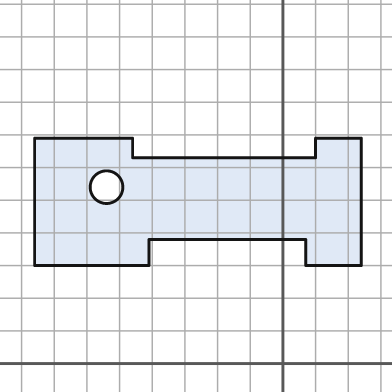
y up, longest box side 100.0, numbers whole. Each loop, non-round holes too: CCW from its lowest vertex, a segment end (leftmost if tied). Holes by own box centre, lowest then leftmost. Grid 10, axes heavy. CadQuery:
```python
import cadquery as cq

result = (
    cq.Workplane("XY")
    .moveTo(-76.0, 30.0)
    .lineTo(-41.0, 30.0)
    .lineTo(-41.0, 38.0)
    .lineTo(7.0, 38.0)
    .lineTo(7.0, 30.0)
    .lineTo(24.0, 30.0)
    .lineTo(24.0, 69.0)
    .lineTo(10.0, 69.0)
    .lineTo(10.0, 63.0)
    .lineTo(-46.0, 63.0)
    .lineTo(-46.0, 69.0)
    .lineTo(-76.0, 69.0)
    .close()
    .moveTo(-54.0, 54.0)
    .circle(5.0)
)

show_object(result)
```